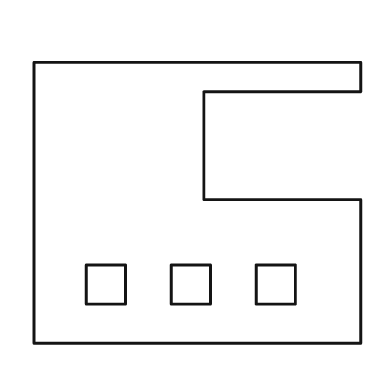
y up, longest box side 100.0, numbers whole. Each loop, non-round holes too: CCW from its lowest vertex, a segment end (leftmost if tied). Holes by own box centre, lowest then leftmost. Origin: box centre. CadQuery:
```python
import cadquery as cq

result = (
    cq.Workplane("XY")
    .moveTo(-50.0, -43.0)
    .lineTo(50.0, -43.0)
    .lineTo(50.0, 1.0)
    .lineTo(2.0, 1.0)
    .lineTo(2.0, 34.0)
    .lineTo(50.0, 34.0)
    .lineTo(50.0, 43.0)
    .lineTo(-50.0, 43.0)
    .close()
    .moveTo(-34.0, -31.0)
    .lineTo(-22.0, -31.0)
    .lineTo(-22.0, -19.0)
    .lineTo(-34.0, -19.0)
    .close()
    .moveTo(-8.0, -31.0)
    .lineTo(4.0, -31.0)
    .lineTo(4.0, -19.0)
    .lineTo(-8.0, -19.0)
    .close()
    .moveTo(18.0, -31.0)
    .lineTo(30.0, -31.0)
    .lineTo(30.0, -19.0)
    .lineTo(18.0, -19.0)
    .close()
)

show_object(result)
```